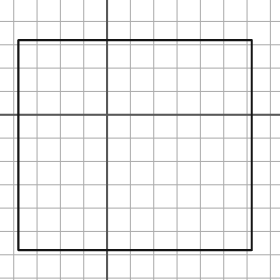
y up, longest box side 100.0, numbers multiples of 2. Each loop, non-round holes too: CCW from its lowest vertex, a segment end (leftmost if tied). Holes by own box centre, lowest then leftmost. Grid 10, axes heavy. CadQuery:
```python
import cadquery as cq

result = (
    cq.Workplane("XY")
    .moveTo(-38.0, -58.0)
    .lineTo(62.0, -58.0)
    .lineTo(62.0, 32.0)
    .lineTo(-38.0, 32.0)
    .close()
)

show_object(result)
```